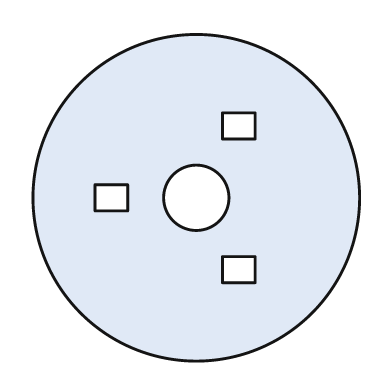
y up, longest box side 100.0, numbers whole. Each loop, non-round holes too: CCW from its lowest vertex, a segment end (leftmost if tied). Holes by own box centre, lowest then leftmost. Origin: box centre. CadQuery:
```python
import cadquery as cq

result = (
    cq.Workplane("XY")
    .moveTo(0.0, 0.0)
    .circle(50.0)
    .moveTo(8.0, -26.0)
    .lineTo(18.0, -26.0)
    .lineTo(18.0, -18.0)
    .lineTo(8.0, -18.0)
    .close()
    .moveTo(-31.0, -4.0)
    .lineTo(-21.0, -4.0)
    .lineTo(-21.0, 4.0)
    .lineTo(-31.0, 4.0)
    .close()
    .moveTo(0.0, 0.0)
    .circle(10.0)
    .moveTo(8.0, 18.0)
    .lineTo(18.0, 18.0)
    .lineTo(18.0, 26.0)
    .lineTo(8.0, 26.0)
    .close()
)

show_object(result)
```